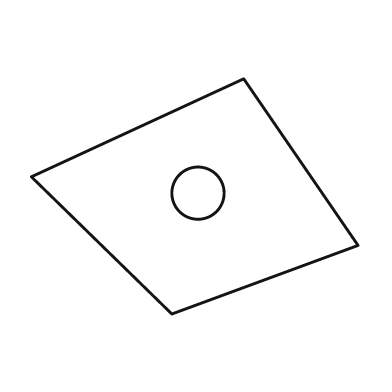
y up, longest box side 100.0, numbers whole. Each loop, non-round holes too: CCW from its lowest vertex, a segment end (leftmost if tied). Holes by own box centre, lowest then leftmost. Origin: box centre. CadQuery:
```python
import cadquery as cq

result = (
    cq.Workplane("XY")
    .moveTo(-7.0, -36.0)
    .lineTo(50.0, -15.0)
    .lineTo(15.0, 36.0)
    .lineTo(-50.0, 6.0)
    .close()
    .moveTo(1.0, 1.0)
    .circle(8.0)
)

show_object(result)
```